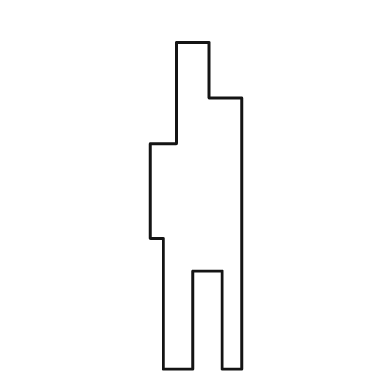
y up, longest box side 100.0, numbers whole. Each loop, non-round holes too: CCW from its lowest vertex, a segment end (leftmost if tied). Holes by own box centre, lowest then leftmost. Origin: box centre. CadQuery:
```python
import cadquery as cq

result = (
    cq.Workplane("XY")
    .moveTo(-10.0, -50.0)
    .lineTo(-1.0, -50.0)
    .lineTo(-1.0, -20.0)
    .lineTo(8.0, -20.0)
    .lineTo(8.0, -50.0)
    .lineTo(14.0, -50.0)
    .lineTo(14.0, 33.0)
    .lineTo(4.0, 33.0)
    .lineTo(4.0, 50.0)
    .lineTo(-6.0, 50.0)
    .lineTo(-6.0, 19.0)
    .lineTo(-14.0, 19.0)
    .lineTo(-14.0, -10.0)
    .lineTo(-10.0, -10.0)
    .close()
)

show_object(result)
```